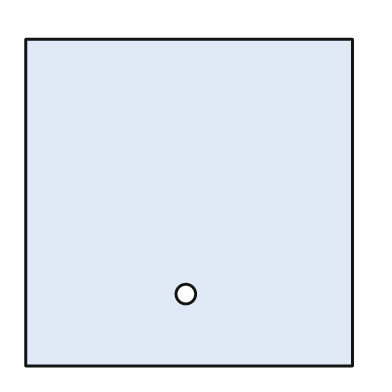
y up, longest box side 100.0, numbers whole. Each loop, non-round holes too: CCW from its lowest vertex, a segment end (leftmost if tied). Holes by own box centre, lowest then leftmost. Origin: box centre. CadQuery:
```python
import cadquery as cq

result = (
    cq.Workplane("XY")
    .moveTo(-50.0, -50.0)
    .lineTo(50.0, -50.0)
    .lineTo(50.0, 50.0)
    .lineTo(-50.0, 50.0)
    .close()
    .moveTo(-1.0, -28.0)
    .circle(3.0)
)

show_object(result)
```